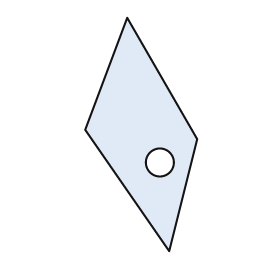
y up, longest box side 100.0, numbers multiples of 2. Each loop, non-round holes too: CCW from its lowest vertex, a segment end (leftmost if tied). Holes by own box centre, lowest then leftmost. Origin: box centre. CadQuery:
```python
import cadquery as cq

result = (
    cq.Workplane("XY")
    .moveTo(12.0, -50.0)
    .lineTo(24.0, -2.0)
    .lineTo(-6.0, 50.0)
    .lineTo(-24.0, 2.0)
    .close()
    .moveTo(8.0, -12.0)
    .circle(6.0)
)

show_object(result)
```